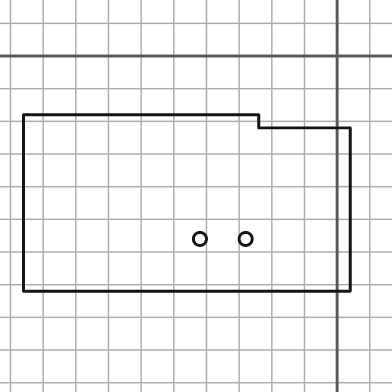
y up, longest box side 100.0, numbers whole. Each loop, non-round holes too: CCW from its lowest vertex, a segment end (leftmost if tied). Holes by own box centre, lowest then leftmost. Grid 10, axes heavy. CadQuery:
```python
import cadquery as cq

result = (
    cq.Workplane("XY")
    .moveTo(-96.0, -72.0)
    .lineTo(4.0, -72.0)
    .lineTo(4.0, -22.0)
    .lineTo(-24.0, -22.0)
    .lineTo(-24.0, -18.0)
    .lineTo(-96.0, -18.0)
    .close()
    .moveTo(-42.0, -56.0)
    .circle(2.0)
    .moveTo(-28.0, -56.0)
    .circle(2.0)
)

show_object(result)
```